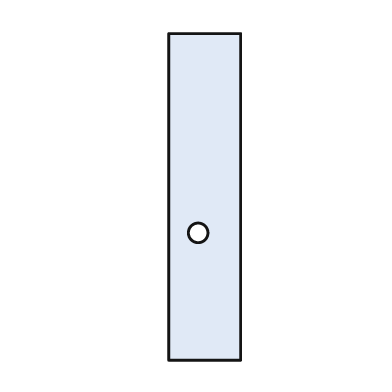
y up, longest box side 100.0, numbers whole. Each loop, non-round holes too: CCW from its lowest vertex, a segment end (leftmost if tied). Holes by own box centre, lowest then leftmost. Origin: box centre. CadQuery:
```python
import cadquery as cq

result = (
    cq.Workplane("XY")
    .moveTo(-11.0, -50.0)
    .lineTo(11.0, -50.0)
    .lineTo(11.0, 50.0)
    .lineTo(-11.0, 50.0)
    .close()
    .moveTo(-2.0, -11.0)
    .circle(3.0)
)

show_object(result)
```